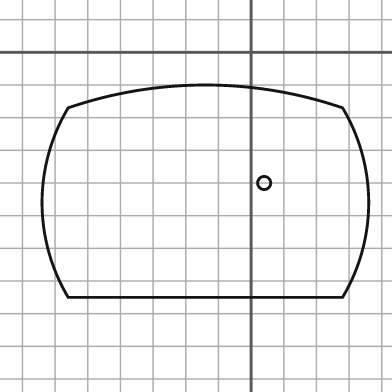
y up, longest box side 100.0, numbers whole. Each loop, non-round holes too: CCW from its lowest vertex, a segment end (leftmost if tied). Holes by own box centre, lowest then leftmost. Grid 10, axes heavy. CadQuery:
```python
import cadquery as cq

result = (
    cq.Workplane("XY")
    .moveTo(-56.0, -75.0)
    .lineTo(28.0, -75.0)
    .threePointArc((36.0, -46.0), (28.0, -17.0))
    .threePointArc((-14.0, -10.0), (-56.0, -17.0))
    .threePointArc((-64.0, -46.0), (-56.0, -75.0))
    .close()
    .moveTo(4.0, -40.0)
    .circle(2.0)
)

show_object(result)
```